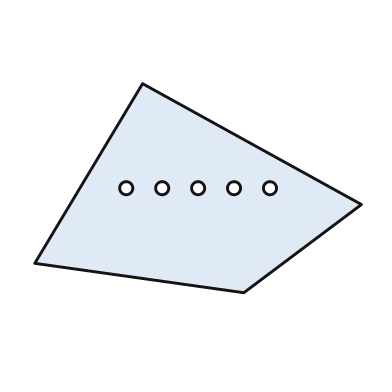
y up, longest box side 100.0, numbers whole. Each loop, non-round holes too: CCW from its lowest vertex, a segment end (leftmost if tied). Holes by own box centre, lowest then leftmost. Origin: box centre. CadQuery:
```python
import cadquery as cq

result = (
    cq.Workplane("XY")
    .moveTo(14.0, -32.0)
    .lineTo(50.0, -5.0)
    .lineTo(-17.0, 32.0)
    .lineTo(-50.0, -23.0)
    .close()
    .moveTo(-22.0, 0.0)
    .circle(2.0)
    .moveTo(-11.0, 0.0)
    .circle(2.0)
    .moveTo(0.0, 0.0)
    .circle(2.0)
    .moveTo(11.0, 0.0)
    .circle(2.0)
    .moveTo(22.0, 0.0)
    .circle(2.0)
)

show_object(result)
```